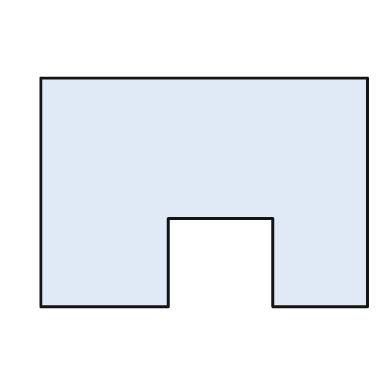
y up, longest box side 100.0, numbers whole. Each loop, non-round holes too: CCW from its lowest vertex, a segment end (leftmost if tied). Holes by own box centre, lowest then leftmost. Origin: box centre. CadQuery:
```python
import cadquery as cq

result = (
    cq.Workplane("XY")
    .moveTo(-50.0, -35.0)
    .lineTo(-11.0, -35.0)
    .lineTo(-11.0, -8.0)
    .lineTo(21.0, -8.0)
    .lineTo(21.0, -35.0)
    .lineTo(50.0, -35.0)
    .lineTo(50.0, 35.0)
    .lineTo(-50.0, 35.0)
    .close()
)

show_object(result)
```